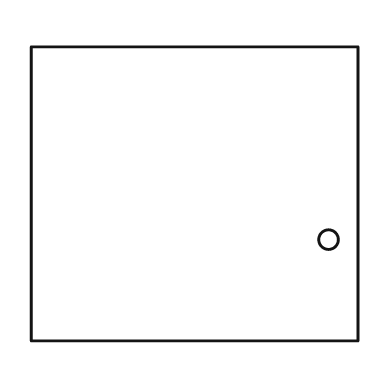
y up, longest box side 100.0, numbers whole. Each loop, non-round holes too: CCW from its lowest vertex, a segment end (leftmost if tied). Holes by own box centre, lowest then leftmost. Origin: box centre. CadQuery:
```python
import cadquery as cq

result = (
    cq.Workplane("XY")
    .moveTo(-50.0, -45.0)
    .lineTo(50.0, -45.0)
    .lineTo(50.0, 45.0)
    .lineTo(-50.0, 45.0)
    .close()
    .moveTo(41.0, -14.0)
    .circle(3.0)
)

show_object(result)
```